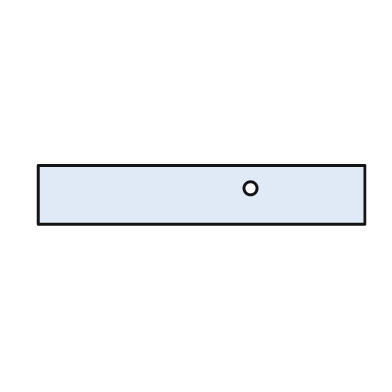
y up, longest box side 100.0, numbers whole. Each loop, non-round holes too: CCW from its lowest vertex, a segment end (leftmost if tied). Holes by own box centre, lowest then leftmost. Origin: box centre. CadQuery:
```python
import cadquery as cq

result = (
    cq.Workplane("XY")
    .moveTo(-50.0, -9.0)
    .lineTo(50.0, -9.0)
    .lineTo(50.0, 9.0)
    .lineTo(-50.0, 9.0)
    .close()
    .moveTo(15.0, 2.0)
    .circle(2.0)
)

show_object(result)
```